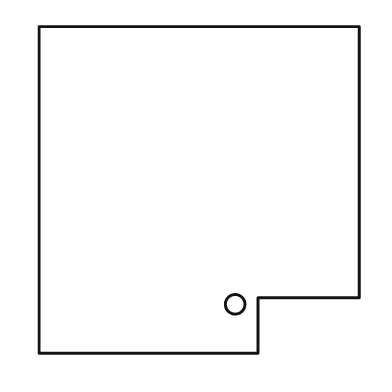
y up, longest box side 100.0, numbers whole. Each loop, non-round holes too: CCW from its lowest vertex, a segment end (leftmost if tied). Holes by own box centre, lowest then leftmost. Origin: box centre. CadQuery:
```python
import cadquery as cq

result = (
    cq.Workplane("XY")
    .moveTo(-49.0, -50.0)
    .lineTo(18.0, -50.0)
    .lineTo(18.0, -33.0)
    .lineTo(49.0, -33.0)
    .lineTo(49.0, 50.0)
    .lineTo(-49.0, 50.0)
    .close()
    .moveTo(11.0, -35.0)
    .circle(3.0)
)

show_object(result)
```